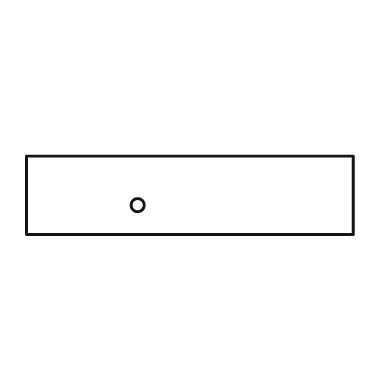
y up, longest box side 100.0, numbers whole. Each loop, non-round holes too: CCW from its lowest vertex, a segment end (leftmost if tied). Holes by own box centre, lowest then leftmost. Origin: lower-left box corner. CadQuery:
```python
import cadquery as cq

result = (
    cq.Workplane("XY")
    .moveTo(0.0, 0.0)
    .lineTo(100.0, 0.0)
    .lineTo(100.0, 24.0)
    .lineTo(0.0, 24.0)
    .close()
    .moveTo(34.0, 9.0)
    .circle(2.0)
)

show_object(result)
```